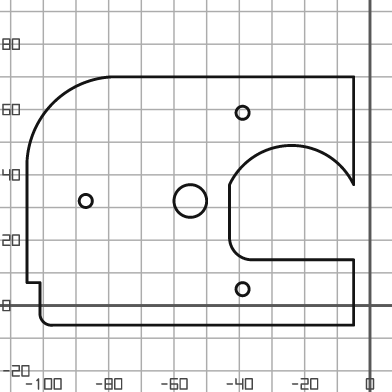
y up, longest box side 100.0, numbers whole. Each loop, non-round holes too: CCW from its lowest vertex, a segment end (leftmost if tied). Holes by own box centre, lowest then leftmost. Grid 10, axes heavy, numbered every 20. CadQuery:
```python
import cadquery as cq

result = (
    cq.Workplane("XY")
    .moveTo(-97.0, -6.0)
    .lineTo(-5.0, -6.0)
    .lineTo(-5.0, 14.0)
    .lineTo(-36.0, 14.0)
    .threePointArc((-41.0, 16.0), (-43.0, 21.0))
    .lineTo(-43.0, 37.0)
    .threePointArc((-24.0, 49.0), (-5.0, 37.0))
    .lineTo(-5.0, 70.0)
    .lineTo(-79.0, 70.0)
    .threePointArc((-97.0, 62.0), (-105.0, 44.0))
    .lineTo(-105.0, 7.0)
    .lineTo(-101.0, 7.0)
    .lineTo(-101.0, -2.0)
    .threePointArc((-100.0, -5.0), (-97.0, -6.0))
    .close()
    .moveTo(-39.0, 5.0)
    .circle(2.0)
    .moveTo(-87.0, 32.0)
    .circle(2.0)
    .moveTo(-55.0, 32.0)
    .circle(5.0)
    .moveTo(-39.0, 59.0)
    .circle(2.0)
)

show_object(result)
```